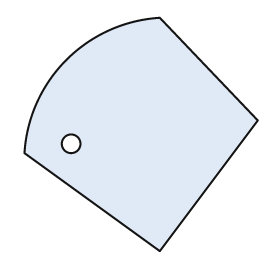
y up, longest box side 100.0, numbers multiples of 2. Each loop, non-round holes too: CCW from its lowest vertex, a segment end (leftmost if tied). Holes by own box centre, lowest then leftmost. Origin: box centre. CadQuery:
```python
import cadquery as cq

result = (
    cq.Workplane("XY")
    .moveTo(8.0, -50.0)
    .lineTo(50.0, 6.0)
    .lineTo(8.0, 50.0)
    .threePointArc((-32.0, 32.0), (-50.0, -8.0))
    .close()
    .moveTo(-30.0, -4.0)
    .circle(4.0)
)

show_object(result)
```